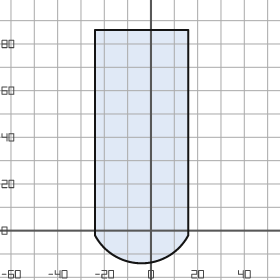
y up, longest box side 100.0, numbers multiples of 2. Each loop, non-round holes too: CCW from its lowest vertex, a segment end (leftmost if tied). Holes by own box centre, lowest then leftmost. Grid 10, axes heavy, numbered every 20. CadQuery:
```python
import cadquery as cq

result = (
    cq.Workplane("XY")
    .moveTo(-24.0, -2.0)
    .threePointArc((-4.0, -14.0), (16.0, -2.0))
    .lineTo(16.0, 86.0)
    .lineTo(-24.0, 86.0)
    .close()
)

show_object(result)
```